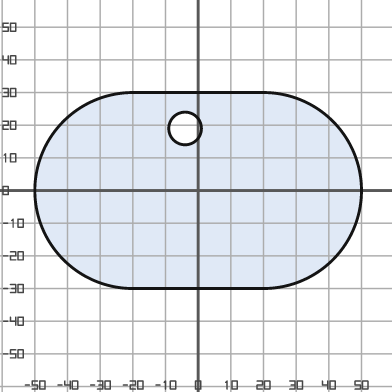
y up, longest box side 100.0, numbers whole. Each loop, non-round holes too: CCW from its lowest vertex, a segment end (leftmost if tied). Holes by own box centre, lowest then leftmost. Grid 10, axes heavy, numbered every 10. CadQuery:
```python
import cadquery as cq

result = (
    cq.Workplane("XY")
    .moveTo(-20.0, -30.0)
    .lineTo(20.0, -30.0)
    .threePointArc((50.0, 0.0), (20.0, 30.0))
    .lineTo(-20.0, 30.0)
    .threePointArc((-50.0, 0.0), (-20.0, -30.0))
    .close()
    .moveTo(-4.0, 19.0)
    .circle(5.0)
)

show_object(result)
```